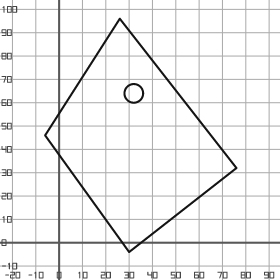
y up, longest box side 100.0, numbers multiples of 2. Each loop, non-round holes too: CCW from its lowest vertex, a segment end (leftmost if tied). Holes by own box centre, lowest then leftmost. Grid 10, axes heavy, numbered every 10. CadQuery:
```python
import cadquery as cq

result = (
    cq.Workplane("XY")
    .moveTo(30.0, -4.0)
    .lineTo(76.0, 32.0)
    .lineTo(26.0, 96.0)
    .lineTo(-6.0, 46.0)
    .close()
    .moveTo(32.0, 64.0)
    .circle(4.0)
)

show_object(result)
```